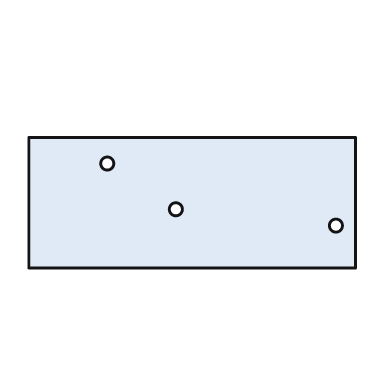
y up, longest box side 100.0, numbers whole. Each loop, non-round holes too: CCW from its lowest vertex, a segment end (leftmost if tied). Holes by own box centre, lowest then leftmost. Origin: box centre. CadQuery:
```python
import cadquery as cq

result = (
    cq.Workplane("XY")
    .moveTo(-50.0, -20.0)
    .lineTo(50.0, -20.0)
    .lineTo(50.0, 20.0)
    .lineTo(-50.0, 20.0)
    .close()
    .moveTo(44.0, -7.0)
    .circle(2.0)
    .moveTo(-5.0, -2.0)
    .circle(2.0)
    .moveTo(-26.0, 12.0)
    .circle(2.0)
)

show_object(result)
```